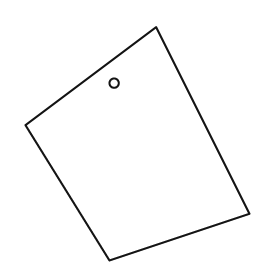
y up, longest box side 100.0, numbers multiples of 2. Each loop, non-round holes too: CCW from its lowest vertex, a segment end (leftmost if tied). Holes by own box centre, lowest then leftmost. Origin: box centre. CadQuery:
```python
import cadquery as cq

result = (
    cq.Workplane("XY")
    .moveTo(-12.0, -50.0)
    .lineTo(48.0, -30.0)
    .lineTo(8.0, 50.0)
    .lineTo(-48.0, 8.0)
    .close()
    .moveTo(-10.0, 26.0)
    .circle(2.0)
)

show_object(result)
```